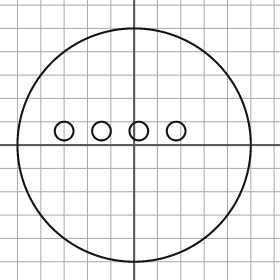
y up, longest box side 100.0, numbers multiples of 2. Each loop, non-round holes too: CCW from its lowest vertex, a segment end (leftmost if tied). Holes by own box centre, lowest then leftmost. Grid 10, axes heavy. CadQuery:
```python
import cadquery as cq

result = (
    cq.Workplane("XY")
    .moveTo(0.0, 0.0)
    .circle(50.0)
    .moveTo(-30.0, 6.0)
    .circle(4.0)
    .moveTo(-14.0, 6.0)
    .circle(4.0)
    .moveTo(2.0, 6.0)
    .circle(4.0)
    .moveTo(18.0, 6.0)
    .circle(4.0)
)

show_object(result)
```